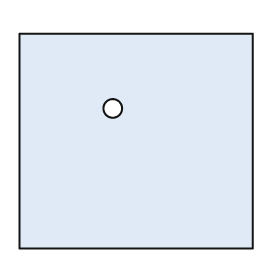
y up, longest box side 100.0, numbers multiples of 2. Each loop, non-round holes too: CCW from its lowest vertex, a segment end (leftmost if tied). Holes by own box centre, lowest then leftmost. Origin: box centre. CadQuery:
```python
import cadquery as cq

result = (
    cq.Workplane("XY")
    .moveTo(-50.0, -46.0)
    .lineTo(50.0, -46.0)
    .lineTo(50.0, 46.0)
    .lineTo(-50.0, 46.0)
    .close()
    .moveTo(-10.0, 14.0)
    .circle(4.0)
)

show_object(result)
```